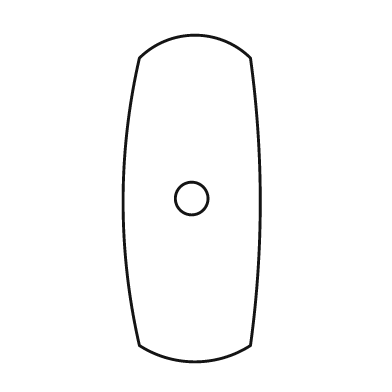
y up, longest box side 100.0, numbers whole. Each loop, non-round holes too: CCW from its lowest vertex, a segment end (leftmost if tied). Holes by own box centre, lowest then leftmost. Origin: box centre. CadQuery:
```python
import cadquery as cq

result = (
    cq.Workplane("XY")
    .moveTo(-16.0, -45.0)
    .threePointArc((1.0, -50.0), (18.0, -45.0))
    .threePointArc((21.0, -1.0), (18.0, 43.0))
    .threePointArc((1.0, 50.0), (-16.0, 43.0))
    .threePointArc((-21.0, -1.0), (-16.0, -45.0))
    .close()
    .moveTo(0.0, 0.0)
    .circle(5.0)
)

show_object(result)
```